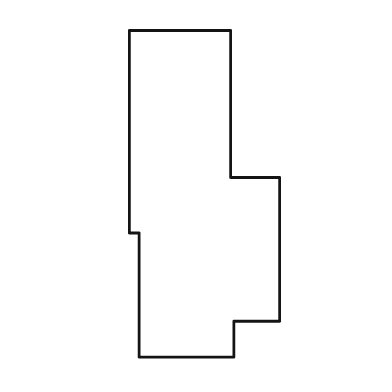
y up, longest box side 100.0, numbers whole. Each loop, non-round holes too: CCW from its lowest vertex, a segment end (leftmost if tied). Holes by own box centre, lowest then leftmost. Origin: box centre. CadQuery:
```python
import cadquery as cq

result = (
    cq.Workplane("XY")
    .moveTo(-20.0, -50.0)
    .lineTo(9.0, -50.0)
    .lineTo(9.0, -39.0)
    .lineTo(23.0, -39.0)
    .lineTo(23.0, 5.0)
    .lineTo(8.0, 5.0)
    .lineTo(8.0, 50.0)
    .lineTo(-23.0, 50.0)
    .lineTo(-23.0, -12.0)
    .lineTo(-20.0, -12.0)
    .close()
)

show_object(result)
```